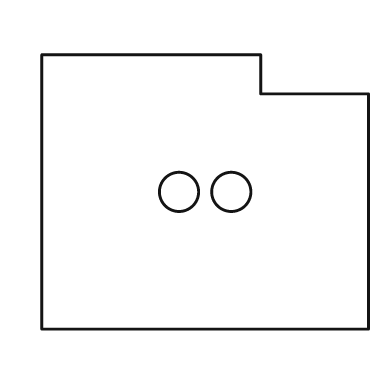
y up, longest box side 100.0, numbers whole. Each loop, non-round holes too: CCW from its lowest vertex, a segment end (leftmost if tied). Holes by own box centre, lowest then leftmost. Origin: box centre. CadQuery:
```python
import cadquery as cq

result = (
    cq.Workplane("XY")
    .moveTo(-50.0, -42.0)
    .lineTo(50.0, -42.0)
    .lineTo(50.0, 30.0)
    .lineTo(17.0, 30.0)
    .lineTo(17.0, 42.0)
    .lineTo(-50.0, 42.0)
    .close()
    .moveTo(-8.0, 0.0)
    .circle(6.0)
    .moveTo(8.0, 0.0)
    .circle(6.0)
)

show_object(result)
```